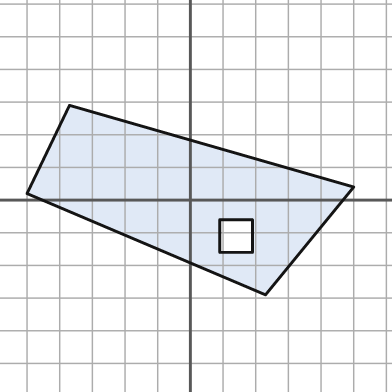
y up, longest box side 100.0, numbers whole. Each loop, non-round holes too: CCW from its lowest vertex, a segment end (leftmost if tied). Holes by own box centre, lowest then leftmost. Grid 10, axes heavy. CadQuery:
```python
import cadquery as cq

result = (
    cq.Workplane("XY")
    .moveTo(23.0, -29.0)
    .lineTo(50.0, 4.0)
    .lineTo(-37.0, 29.0)
    .lineTo(-50.0, 2.0)
    .close()
    .moveTo(9.0, -16.0)
    .lineTo(19.0, -16.0)
    .lineTo(19.0, -6.0)
    .lineTo(9.0, -6.0)
    .close()
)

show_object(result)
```